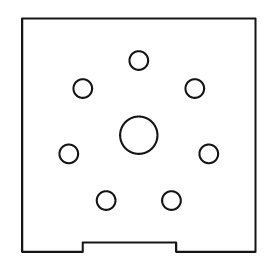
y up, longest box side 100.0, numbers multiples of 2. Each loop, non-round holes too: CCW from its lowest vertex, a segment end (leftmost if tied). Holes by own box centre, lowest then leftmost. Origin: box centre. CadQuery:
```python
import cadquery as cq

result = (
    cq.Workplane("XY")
    .moveTo(-50.0, -50.0)
    .lineTo(-24.0, -50.0)
    .lineTo(-24.0, -46.0)
    .lineTo(16.0, -46.0)
    .lineTo(16.0, -50.0)
    .lineTo(50.0, -50.0)
    .lineTo(50.0, 50.0)
    .lineTo(-50.0, 50.0)
    .close()
    .moveTo(-14.0, -28.0)
    .circle(4.0)
    .moveTo(14.0, -28.0)
    .circle(4.0)
    .moveTo(-30.0, -8.0)
    .circle(4.0)
    .moveTo(30.0, -8.0)
    .circle(4.0)
    .moveTo(0.0, 0.0)
    .circle(8.0)
    .moveTo(-24.0, 20.0)
    .circle(4.0)
    .moveTo(24.0, 20.0)
    .circle(4.0)
    .moveTo(0.0, 32.0)
    .circle(4.0)
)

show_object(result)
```